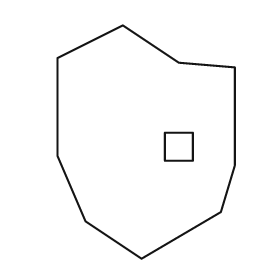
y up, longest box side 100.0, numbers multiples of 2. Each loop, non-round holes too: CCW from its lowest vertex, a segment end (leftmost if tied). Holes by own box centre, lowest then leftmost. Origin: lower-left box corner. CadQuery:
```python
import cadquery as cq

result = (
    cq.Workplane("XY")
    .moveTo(36.0, 0.0)
    .lineTo(70.0, 20.0)
    .lineTo(76.0, 40.0)
    .lineTo(76.0, 82.0)
    .lineTo(52.0, 84.0)
    .lineTo(28.0, 100.0)
    .lineTo(0.0, 86.0)
    .lineTo(0.0, 44.0)
    .lineTo(12.0, 16.0)
    .close()
    .moveTo(46.0, 42.0)
    .lineTo(58.0, 42.0)
    .lineTo(58.0, 54.0)
    .lineTo(46.0, 54.0)
    .close()
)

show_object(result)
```